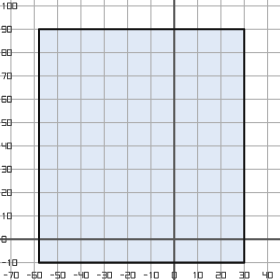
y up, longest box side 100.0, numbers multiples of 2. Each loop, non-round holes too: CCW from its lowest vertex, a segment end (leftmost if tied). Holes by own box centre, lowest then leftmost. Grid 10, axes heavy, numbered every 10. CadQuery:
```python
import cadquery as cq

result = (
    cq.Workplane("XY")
    .moveTo(-58.0, -10.0)
    .lineTo(30.0, -10.0)
    .lineTo(30.0, 90.0)
    .lineTo(-58.0, 90.0)
    .close()
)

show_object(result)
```